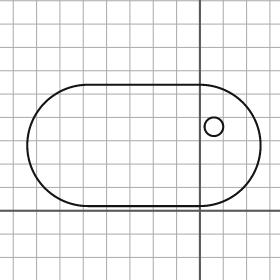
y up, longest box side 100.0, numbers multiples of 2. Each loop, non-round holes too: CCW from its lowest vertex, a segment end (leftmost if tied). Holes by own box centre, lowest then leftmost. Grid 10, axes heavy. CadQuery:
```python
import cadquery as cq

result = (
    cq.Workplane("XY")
    .moveTo(-48.0, 2.0)
    .lineTo(0.0, 2.0)
    .threePointArc((26.0, 28.0), (0.0, 54.0))
    .lineTo(-48.0, 54.0)
    .threePointArc((-74.0, 28.0), (-48.0, 2.0))
    .close()
    .moveTo(6.0, 36.0)
    .circle(4.0)
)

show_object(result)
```